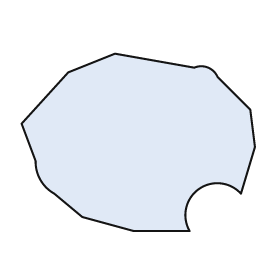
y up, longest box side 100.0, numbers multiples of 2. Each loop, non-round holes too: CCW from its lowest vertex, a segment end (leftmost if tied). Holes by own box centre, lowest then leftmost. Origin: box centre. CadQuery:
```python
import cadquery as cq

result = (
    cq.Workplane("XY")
    .moveTo(-2.0, -38.0)
    .lineTo(22.0, -38.0)
    .threePointArc((26.0, -20.0), (44.0, -22.0))
    .lineTo(50.0, -2.0)
    .lineTo(48.0, 14.0)
    .lineTo(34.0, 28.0)
    .threePointArc((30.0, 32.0), (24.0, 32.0))
    .lineTo(-10.0, 38.0)
    .lineTo(-30.0, 30.0)
    .lineTo(-50.0, 8.0)
    .lineTo(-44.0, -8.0)
    .threePointArc((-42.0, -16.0), (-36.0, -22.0))
    .lineTo(-24.0, -32.0)
    .close()
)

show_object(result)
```